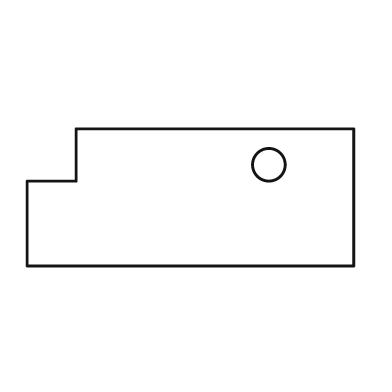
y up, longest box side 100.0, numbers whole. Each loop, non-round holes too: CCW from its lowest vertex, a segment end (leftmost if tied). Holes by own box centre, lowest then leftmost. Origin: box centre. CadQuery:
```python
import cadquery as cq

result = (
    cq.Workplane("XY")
    .moveTo(-50.0, -21.0)
    .lineTo(50.0, -21.0)
    .lineTo(50.0, 21.0)
    .lineTo(-35.0, 21.0)
    .lineTo(-35.0, 5.0)
    .lineTo(-50.0, 5.0)
    .close()
    .moveTo(24.0, 10.0)
    .circle(5.0)
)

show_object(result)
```